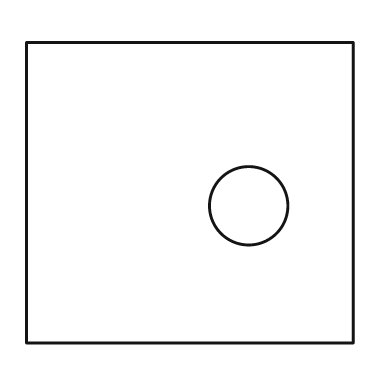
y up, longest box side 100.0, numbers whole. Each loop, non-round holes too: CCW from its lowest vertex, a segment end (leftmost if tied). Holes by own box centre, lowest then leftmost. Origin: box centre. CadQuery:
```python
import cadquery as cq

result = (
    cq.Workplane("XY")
    .moveTo(-50.0, -46.0)
    .lineTo(50.0, -46.0)
    .lineTo(50.0, 46.0)
    .lineTo(-50.0, 46.0)
    .close()
    .moveTo(18.0, -4.0)
    .circle(12.0)
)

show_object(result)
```